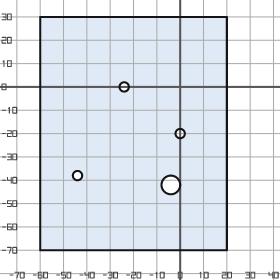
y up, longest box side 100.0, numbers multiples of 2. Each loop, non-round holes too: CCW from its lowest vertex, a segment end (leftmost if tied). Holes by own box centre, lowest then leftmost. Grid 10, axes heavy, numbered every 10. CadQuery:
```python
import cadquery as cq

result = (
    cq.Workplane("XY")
    .moveTo(-60.0, -70.0)
    .lineTo(20.0, -70.0)
    .lineTo(20.0, 30.0)
    .lineTo(-60.0, 30.0)
    .close()
    .moveTo(-4.0, -42.0)
    .circle(4.0)
    .moveTo(-44.0, -38.0)
    .circle(2.0)
    .moveTo(0.0, -20.0)
    .circle(2.0)
    .moveTo(-24.0, 0.0)
    .circle(2.0)
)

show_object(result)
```